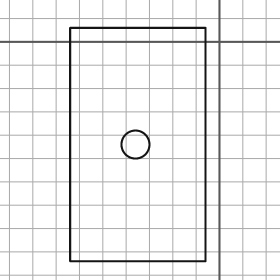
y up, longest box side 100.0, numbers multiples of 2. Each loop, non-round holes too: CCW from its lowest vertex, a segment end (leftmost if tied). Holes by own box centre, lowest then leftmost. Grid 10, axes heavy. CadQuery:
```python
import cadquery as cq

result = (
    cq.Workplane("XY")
    .moveTo(-64.0, -94.0)
    .lineTo(-6.0, -94.0)
    .lineTo(-6.0, 6.0)
    .lineTo(-64.0, 6.0)
    .close()
    .moveTo(-36.0, -44.0)
    .circle(6.0)
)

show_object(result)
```